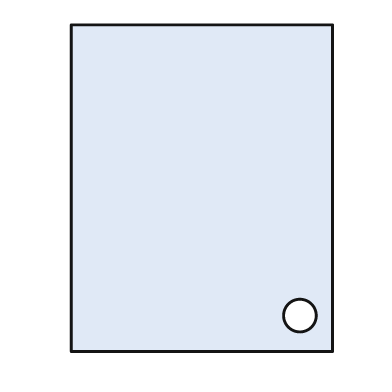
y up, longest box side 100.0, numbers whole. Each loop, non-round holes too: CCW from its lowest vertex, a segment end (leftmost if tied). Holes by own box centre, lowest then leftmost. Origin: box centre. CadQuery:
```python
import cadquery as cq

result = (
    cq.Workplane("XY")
    .moveTo(-40.0, -50.0)
    .lineTo(40.0, -50.0)
    .lineTo(40.0, 50.0)
    .lineTo(-40.0, 50.0)
    .close()
    .moveTo(30.0, -39.0)
    .circle(5.0)
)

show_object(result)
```